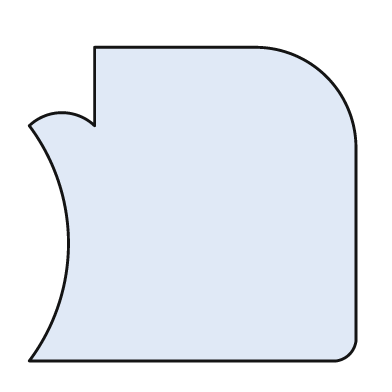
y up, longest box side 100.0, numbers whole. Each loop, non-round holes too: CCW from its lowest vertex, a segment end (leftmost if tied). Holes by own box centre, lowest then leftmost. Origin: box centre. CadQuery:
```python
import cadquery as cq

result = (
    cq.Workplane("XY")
    .moveTo(-50.0, -48.0)
    .lineTo(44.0, -48.0)
    .threePointArc((48.0, -46.0), (50.0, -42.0))
    .lineTo(50.0, 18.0)
    .threePointArc((41.0, 39.0), (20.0, 48.0))
    .lineTo(-30.0, 48.0)
    .lineTo(-30.0, 24.0)
    .threePointArc((-40.0, 28.0), (-50.0, 24.0))
    .threePointArc((-38.0, -12.0), (-50.0, -48.0))
    .close()
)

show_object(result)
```